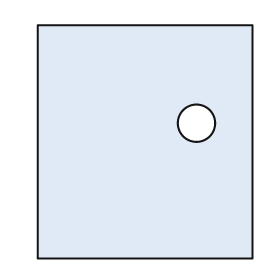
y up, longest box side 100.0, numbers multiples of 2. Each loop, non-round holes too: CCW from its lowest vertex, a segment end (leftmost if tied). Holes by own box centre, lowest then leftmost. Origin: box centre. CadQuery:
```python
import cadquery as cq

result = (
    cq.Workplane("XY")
    .moveTo(-46.0, -50.0)
    .lineTo(46.0, -50.0)
    .lineTo(46.0, 50.0)
    .lineTo(-46.0, 50.0)
    .close()
    .moveTo(22.0, 8.0)
    .circle(8.0)
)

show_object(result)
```